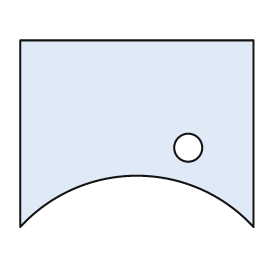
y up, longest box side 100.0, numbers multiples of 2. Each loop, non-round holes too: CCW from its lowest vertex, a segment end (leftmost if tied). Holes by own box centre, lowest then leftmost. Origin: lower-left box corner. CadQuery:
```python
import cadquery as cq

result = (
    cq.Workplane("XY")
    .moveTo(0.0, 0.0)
    .threePointArc((50.0, 22.0), (100.0, 0.0))
    .lineTo(100.0, 80.0)
    .lineTo(0.0, 80.0)
    .close()
    .moveTo(72.0, 34.0)
    .circle(6.0)
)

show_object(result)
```